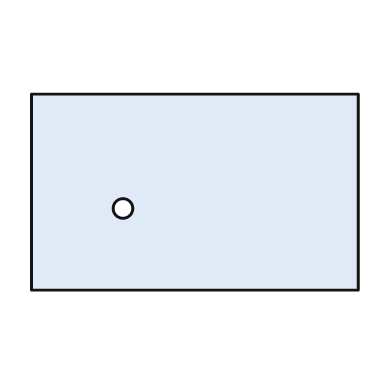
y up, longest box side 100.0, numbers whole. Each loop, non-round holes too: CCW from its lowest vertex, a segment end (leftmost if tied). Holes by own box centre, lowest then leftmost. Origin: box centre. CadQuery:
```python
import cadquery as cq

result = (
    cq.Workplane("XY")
    .moveTo(-50.0, -30.0)
    .lineTo(50.0, -30.0)
    .lineTo(50.0, 30.0)
    .lineTo(-50.0, 30.0)
    .close()
    .moveTo(-22.0, -5.0)
    .circle(3.0)
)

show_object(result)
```